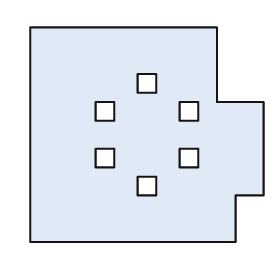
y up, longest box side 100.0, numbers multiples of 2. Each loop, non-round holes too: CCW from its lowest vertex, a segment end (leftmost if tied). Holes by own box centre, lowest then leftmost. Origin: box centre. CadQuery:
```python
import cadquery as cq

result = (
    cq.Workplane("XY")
    .moveTo(-50.0, -46.0)
    .lineTo(38.0, -46.0)
    .lineTo(38.0, -26.0)
    .lineTo(50.0, -26.0)
    .lineTo(50.0, 14.0)
    .lineTo(30.0, 14.0)
    .lineTo(30.0, 46.0)
    .lineTo(-50.0, 46.0)
    .close()
    .moveTo(-4.0, -26.0)
    .lineTo(4.0, -26.0)
    .lineTo(4.0, -18.0)
    .lineTo(-4.0, -18.0)
    .close()
    .moveTo(-22.0, -14.0)
    .lineTo(-14.0, -14.0)
    .lineTo(-14.0, -6.0)
    .lineTo(-22.0, -6.0)
    .close()
    .moveTo(14.0, -14.0)
    .lineTo(22.0, -14.0)
    .lineTo(22.0, -6.0)
    .lineTo(14.0, -6.0)
    .close()
    .moveTo(-22.0, 6.0)
    .lineTo(-14.0, 6.0)
    .lineTo(-14.0, 14.0)
    .lineTo(-22.0, 14.0)
    .close()
    .moveTo(14.0, 6.0)
    .lineTo(22.0, 6.0)
    .lineTo(22.0, 14.0)
    .lineTo(14.0, 14.0)
    .close()
    .moveTo(-4.0, 18.0)
    .lineTo(4.0, 18.0)
    .lineTo(4.0, 26.0)
    .lineTo(-4.0, 26.0)
    .close()
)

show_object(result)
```